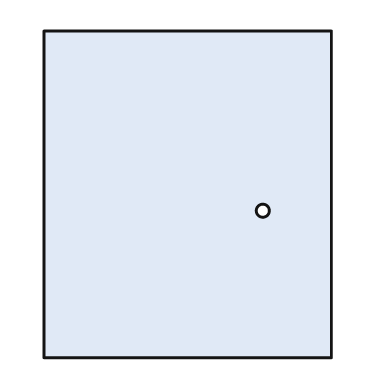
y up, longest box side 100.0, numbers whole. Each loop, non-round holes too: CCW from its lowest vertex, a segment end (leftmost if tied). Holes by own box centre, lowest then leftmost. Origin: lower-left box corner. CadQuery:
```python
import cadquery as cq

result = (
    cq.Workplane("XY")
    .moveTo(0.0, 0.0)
    .lineTo(88.0, 0.0)
    .lineTo(88.0, 100.0)
    .lineTo(0.0, 100.0)
    .close()
    .moveTo(67.0, 45.0)
    .circle(2.0)
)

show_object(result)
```